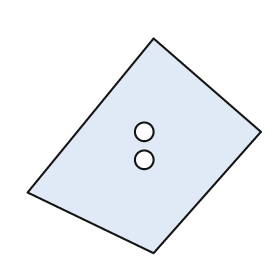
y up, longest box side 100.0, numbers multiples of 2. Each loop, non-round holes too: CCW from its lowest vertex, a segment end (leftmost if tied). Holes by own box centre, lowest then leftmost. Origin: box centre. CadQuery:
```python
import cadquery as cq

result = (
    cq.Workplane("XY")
    .moveTo(4.0, -46.0)
    .lineTo(50.0, 6.0)
    .lineTo(4.0, 46.0)
    .lineTo(-50.0, -20.0)
    .close()
    .moveTo(0.0, -6.0)
    .circle(4.0)
    .moveTo(0.0, 6.0)
    .circle(4.0)
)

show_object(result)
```